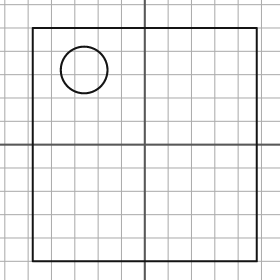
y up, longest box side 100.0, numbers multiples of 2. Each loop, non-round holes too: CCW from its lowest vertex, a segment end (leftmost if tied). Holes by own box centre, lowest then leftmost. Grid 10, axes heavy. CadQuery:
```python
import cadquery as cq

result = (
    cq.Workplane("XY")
    .moveTo(-48.0, -50.0)
    .lineTo(48.0, -50.0)
    .lineTo(48.0, 50.0)
    .lineTo(-48.0, 50.0)
    .close()
    .moveTo(-26.0, 32.0)
    .circle(10.0)
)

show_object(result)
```